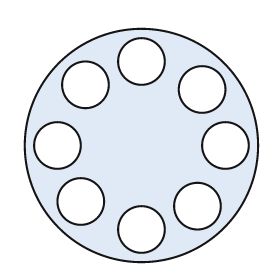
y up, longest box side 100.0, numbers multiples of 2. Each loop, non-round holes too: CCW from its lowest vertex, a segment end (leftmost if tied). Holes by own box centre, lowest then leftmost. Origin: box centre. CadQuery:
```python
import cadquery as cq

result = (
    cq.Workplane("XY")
    .moveTo(0.0, 0.0)
    .circle(50.0)
    .moveTo(0.0, -36.0)
    .circle(10.0)
    .moveTo(24.0, -26.0)
    .circle(10.0)
    .moveTo(-26.0, -24.0)
    .circle(10.0)
    .moveTo(-36.0, 0.0)
    .circle(10.0)
    .moveTo(36.0, 0.0)
    .circle(10.0)
    .moveTo(26.0, 24.0)
    .circle(10.0)
    .moveTo(-24.0, 26.0)
    .circle(10.0)
    .moveTo(0.0, 36.0)
    .circle(10.0)
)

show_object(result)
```